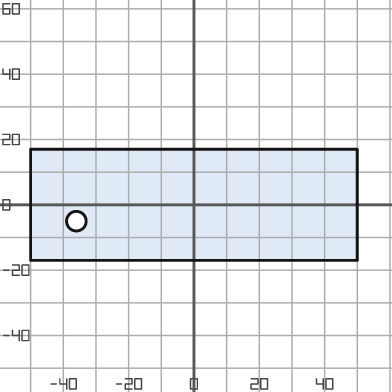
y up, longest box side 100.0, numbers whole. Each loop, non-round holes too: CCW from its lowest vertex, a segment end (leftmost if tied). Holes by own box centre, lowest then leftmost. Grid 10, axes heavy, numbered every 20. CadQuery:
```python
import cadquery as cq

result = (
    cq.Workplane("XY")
    .moveTo(-50.0, -17.0)
    .lineTo(50.0, -17.0)
    .lineTo(50.0, 17.0)
    .lineTo(-50.0, 17.0)
    .close()
    .moveTo(-36.0, -5.0)
    .circle(3.0)
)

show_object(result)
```